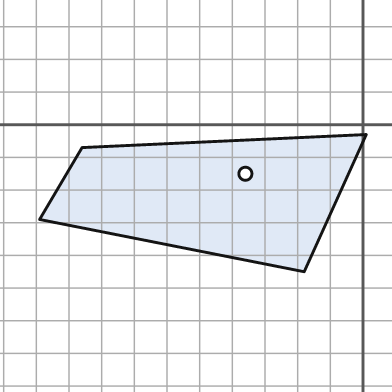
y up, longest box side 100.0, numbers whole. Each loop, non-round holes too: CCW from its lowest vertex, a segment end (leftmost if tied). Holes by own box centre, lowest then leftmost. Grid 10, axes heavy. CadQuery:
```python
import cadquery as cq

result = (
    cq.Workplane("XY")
    .moveTo(-18.0, -45.0)
    .lineTo(1.0, -3.0)
    .lineTo(-86.0, -7.0)
    .lineTo(-99.0, -29.0)
    .close()
    .moveTo(-36.0, -15.0)
    .circle(2.0)
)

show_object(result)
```